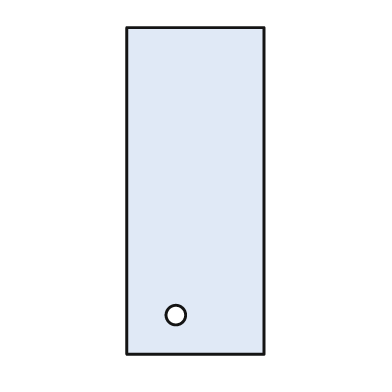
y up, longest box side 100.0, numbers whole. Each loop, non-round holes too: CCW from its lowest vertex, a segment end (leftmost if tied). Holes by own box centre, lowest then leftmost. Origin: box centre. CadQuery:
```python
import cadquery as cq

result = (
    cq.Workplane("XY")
    .moveTo(-21.0, -50.0)
    .lineTo(21.0, -50.0)
    .lineTo(21.0, 50.0)
    .lineTo(-21.0, 50.0)
    .close()
    .moveTo(-6.0, -38.0)
    .circle(3.0)
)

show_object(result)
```